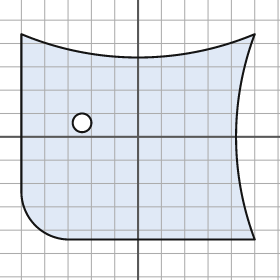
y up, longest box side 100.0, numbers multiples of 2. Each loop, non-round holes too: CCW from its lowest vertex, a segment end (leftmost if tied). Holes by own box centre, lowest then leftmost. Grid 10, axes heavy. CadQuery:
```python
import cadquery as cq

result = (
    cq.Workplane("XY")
    .moveTo(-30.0, -44.0)
    .lineTo(50.0, -44.0)
    .threePointArc((42.0, 0.0), (50.0, 44.0))
    .threePointArc((0.0, 34.0), (-50.0, 44.0))
    .lineTo(-50.0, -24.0)
    .threePointArc((-44.0, -38.0), (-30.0, -44.0))
    .close()
    .moveTo(-24.0, 6.0)
    .circle(4.0)
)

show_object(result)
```